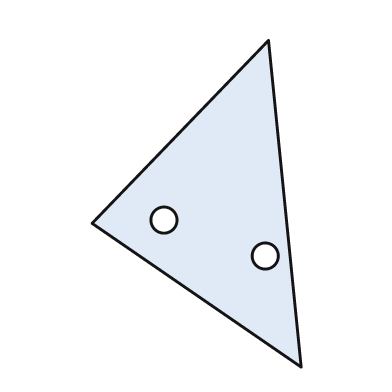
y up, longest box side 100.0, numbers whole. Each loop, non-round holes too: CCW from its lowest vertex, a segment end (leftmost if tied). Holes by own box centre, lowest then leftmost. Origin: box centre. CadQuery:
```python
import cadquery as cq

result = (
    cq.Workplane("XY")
    .moveTo(32.0, -50.0)
    .lineTo(22.0, 50.0)
    .lineTo(-32.0, -6.0)
    .close()
    .moveTo(21.0, -16.0)
    .circle(4.0)
    .moveTo(-10.0, -5.0)
    .circle(4.0)
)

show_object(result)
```